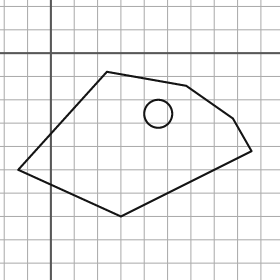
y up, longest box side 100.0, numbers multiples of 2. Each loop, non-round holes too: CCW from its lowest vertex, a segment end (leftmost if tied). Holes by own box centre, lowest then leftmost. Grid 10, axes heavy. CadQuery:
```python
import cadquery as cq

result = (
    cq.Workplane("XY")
    .moveTo(30.0, -70.0)
    .lineTo(86.0, -42.0)
    .lineTo(78.0, -28.0)
    .lineTo(58.0, -14.0)
    .lineTo(24.0, -8.0)
    .lineTo(-14.0, -50.0)
    .close()
    .moveTo(46.0, -26.0)
    .circle(6.0)
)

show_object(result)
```